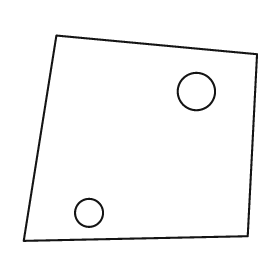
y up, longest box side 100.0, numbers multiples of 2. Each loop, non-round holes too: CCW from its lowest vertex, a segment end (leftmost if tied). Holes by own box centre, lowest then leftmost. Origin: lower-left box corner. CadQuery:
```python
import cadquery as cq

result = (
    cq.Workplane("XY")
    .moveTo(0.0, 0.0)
    .lineTo(96.0, 2.0)
    .lineTo(100.0, 80.0)
    .lineTo(14.0, 88.0)
    .close()
    .moveTo(28.0, 12.0)
    .circle(6.0)
    .moveTo(74.0, 64.0)
    .circle(8.0)
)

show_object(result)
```